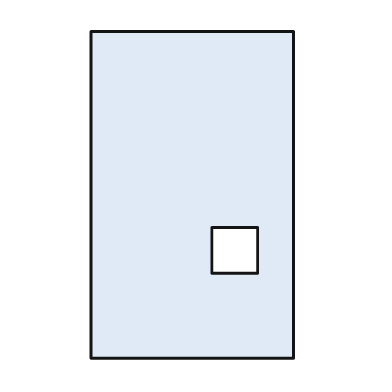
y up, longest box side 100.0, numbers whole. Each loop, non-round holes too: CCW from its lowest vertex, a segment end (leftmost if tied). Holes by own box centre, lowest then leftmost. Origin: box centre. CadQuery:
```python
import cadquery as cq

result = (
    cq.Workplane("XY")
    .moveTo(-31.0, -50.0)
    .lineTo(31.0, -50.0)
    .lineTo(31.0, 50.0)
    .lineTo(-31.0, 50.0)
    .close()
    .moveTo(6.0, -24.0)
    .lineTo(20.0, -24.0)
    .lineTo(20.0, -10.0)
    .lineTo(6.0, -10.0)
    .close()
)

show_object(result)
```